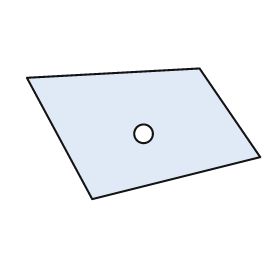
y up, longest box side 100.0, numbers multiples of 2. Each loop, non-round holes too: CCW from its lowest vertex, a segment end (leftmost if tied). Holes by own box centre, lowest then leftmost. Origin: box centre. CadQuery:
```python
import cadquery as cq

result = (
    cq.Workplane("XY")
    .moveTo(-22.0, -28.0)
    .lineTo(50.0, -10.0)
    .lineTo(24.0, 28.0)
    .lineTo(-50.0, 24.0)
    .close()
    .moveTo(0.0, 0.0)
    .circle(4.0)
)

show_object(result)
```